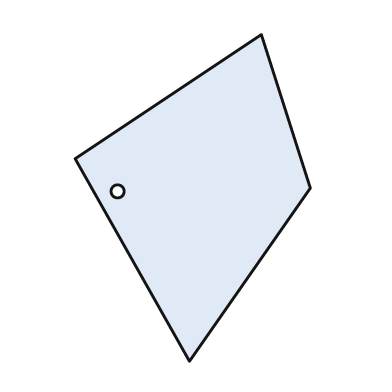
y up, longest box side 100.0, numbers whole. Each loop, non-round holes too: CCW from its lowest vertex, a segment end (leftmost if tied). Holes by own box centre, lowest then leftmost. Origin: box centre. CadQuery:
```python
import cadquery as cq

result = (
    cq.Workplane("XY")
    .moveTo(-1.0, -50.0)
    .lineTo(36.0, 3.0)
    .lineTo(21.0, 50.0)
    .lineTo(-36.0, 12.0)
    .close()
    .moveTo(-23.0, 2.0)
    .circle(2.0)
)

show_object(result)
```